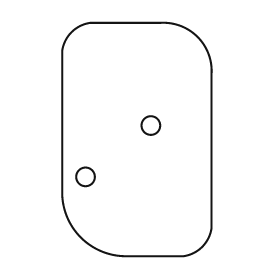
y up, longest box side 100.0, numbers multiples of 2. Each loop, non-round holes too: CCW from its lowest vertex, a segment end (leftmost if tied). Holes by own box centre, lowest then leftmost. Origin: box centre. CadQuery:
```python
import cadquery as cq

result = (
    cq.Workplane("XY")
    .moveTo(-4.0, -50.0)
    .lineTo(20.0, -50.0)
    .threePointArc((28.0, -46.0), (32.0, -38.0))
    .lineTo(32.0, 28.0)
    .threePointArc((26.0, 44.0), (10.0, 50.0))
    .lineTo(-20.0, 50.0)
    .threePointArc((-28.0, 46.0), (-32.0, 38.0))
    .lineTo(-32.0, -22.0)
    .threePointArc((-24.0, -42.0), (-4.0, -50.0))
    .close()
    .moveTo(-22.0, -16.0)
    .circle(4.0)
    .moveTo(6.0, 6.0)
    .circle(4.0)
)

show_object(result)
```